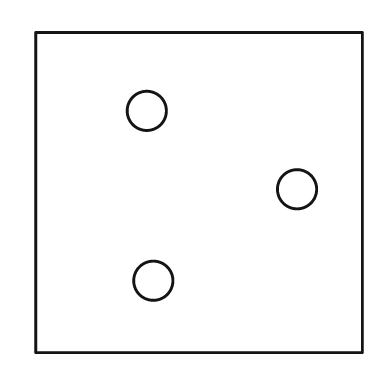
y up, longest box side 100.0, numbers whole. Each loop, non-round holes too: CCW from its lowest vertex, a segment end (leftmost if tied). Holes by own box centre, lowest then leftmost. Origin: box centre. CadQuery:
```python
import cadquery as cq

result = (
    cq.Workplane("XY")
    .moveTo(-50.0, -49.0)
    .lineTo(50.0, -49.0)
    .lineTo(50.0, 49.0)
    .lineTo(-50.0, 49.0)
    .close()
    .moveTo(-14.0, -27.0)
    .circle(6.0)
    .moveTo(30.0, 1.0)
    .circle(6.0)
    .moveTo(-16.0, 25.0)
    .circle(6.0)
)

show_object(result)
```